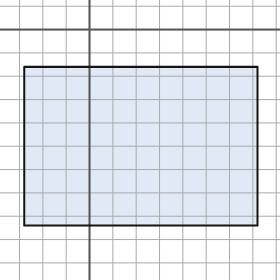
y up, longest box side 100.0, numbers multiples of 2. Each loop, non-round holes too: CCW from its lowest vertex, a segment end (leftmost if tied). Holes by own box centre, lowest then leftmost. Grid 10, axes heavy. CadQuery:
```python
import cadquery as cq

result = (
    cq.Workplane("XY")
    .moveTo(-28.0, -84.0)
    .lineTo(72.0, -84.0)
    .lineTo(72.0, -16.0)
    .lineTo(-28.0, -16.0)
    .close()
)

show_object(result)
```